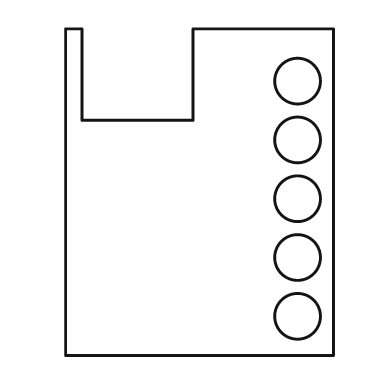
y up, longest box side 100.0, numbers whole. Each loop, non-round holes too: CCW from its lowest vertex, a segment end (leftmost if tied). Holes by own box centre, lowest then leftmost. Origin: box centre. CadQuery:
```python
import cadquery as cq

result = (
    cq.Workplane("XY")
    .moveTo(-41.0, -50.0)
    .lineTo(41.0, -50.0)
    .lineTo(41.0, 50.0)
    .lineTo(-2.0, 50.0)
    .lineTo(-2.0, 22.0)
    .lineTo(-36.0, 22.0)
    .lineTo(-36.0, 50.0)
    .lineTo(-41.0, 50.0)
    .close()
    .moveTo(30.0, -38.0)
    .circle(7.0)
    .moveTo(30.0, -20.0)
    .circle(7.0)
    .moveTo(30.0, -2.0)
    .circle(7.0)
    .moveTo(30.0, 16.0)
    .circle(7.0)
    .moveTo(30.0, 34.0)
    .circle(7.0)
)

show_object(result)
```